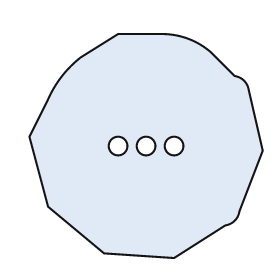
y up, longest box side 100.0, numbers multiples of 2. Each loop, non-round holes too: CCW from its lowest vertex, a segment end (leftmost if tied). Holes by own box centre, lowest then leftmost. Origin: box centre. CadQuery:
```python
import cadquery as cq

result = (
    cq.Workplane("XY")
    .moveTo(12.0, -48.0)
    .lineTo(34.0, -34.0)
    .threePointArc((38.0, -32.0), (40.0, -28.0))
    .lineTo(50.0, -2.0)
    .lineTo(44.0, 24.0)
    .threePointArc((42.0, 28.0), (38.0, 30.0))
    .lineTo(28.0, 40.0)
    .threePointArc((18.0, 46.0), (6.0, 48.0))
    .lineTo(-12.0, 48.0)
    .lineTo(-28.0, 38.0)
    .threePointArc((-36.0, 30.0), (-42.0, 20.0))
    .lineTo(-50.0, 4.0)
    .lineTo(-42.0, -26.0)
    .lineTo(-18.0, -46.0)
    .close()
    .moveTo(-12.0, 0.0)
    .circle(4.0)
    .moveTo(0.0, 0.0)
    .circle(4.0)
    .moveTo(12.0, 0.0)
    .circle(4.0)
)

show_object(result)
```